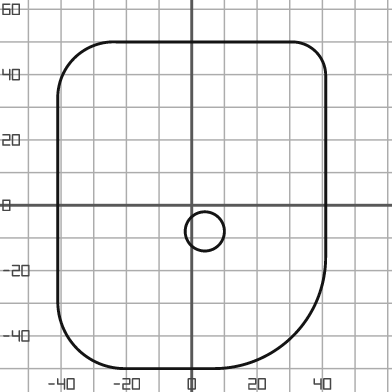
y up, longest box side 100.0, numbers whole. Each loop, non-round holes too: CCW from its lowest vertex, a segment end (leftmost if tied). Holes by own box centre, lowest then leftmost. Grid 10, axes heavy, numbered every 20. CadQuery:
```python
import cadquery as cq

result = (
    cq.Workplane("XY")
    .moveTo(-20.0, -50.0)
    .lineTo(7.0, -50.0)
    .threePointArc((31.0, -40.0), (41.0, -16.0))
    .lineTo(41.0, 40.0)
    .threePointArc((38.0, 47.0), (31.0, 50.0))
    .lineTo(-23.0, 50.0)
    .threePointArc((-36.0, 45.0), (-41.0, 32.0))
    .lineTo(-41.0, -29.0)
    .threePointArc((-35.0, -44.0), (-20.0, -50.0))
    .close()
    .moveTo(4.0, -8.0)
    .circle(6.0)
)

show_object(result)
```